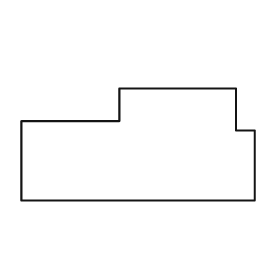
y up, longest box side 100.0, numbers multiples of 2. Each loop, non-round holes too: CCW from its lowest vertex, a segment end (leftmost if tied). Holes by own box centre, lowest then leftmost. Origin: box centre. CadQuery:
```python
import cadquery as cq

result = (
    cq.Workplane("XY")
    .moveTo(-50.0, -24.0)
    .lineTo(50.0, -24.0)
    .lineTo(50.0, 6.0)
    .lineTo(42.0, 6.0)
    .lineTo(42.0, 24.0)
    .lineTo(-8.0, 24.0)
    .lineTo(-8.0, 10.0)
    .lineTo(-50.0, 10.0)
    .close()
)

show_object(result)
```